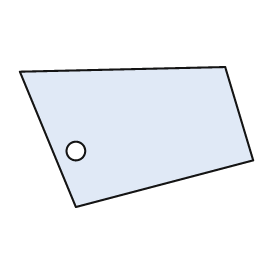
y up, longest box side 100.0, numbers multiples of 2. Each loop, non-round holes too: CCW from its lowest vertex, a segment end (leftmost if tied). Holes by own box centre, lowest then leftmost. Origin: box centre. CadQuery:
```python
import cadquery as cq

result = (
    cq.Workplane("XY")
    .moveTo(-26.0, -30.0)
    .lineTo(50.0, -10.0)
    .lineTo(38.0, 30.0)
    .lineTo(-50.0, 28.0)
    .close()
    .moveTo(-26.0, -6.0)
    .circle(4.0)
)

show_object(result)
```